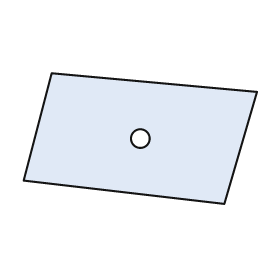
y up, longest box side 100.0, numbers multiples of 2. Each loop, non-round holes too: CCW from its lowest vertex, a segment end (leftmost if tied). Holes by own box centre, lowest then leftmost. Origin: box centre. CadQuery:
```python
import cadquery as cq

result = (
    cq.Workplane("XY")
    .moveTo(36.0, -28.0)
    .lineTo(50.0, 20.0)
    .lineTo(-38.0, 28.0)
    .lineTo(-50.0, -18.0)
    .close()
    .moveTo(0.0, 0.0)
    .circle(4.0)
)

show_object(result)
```